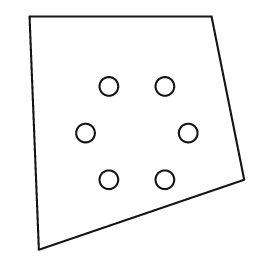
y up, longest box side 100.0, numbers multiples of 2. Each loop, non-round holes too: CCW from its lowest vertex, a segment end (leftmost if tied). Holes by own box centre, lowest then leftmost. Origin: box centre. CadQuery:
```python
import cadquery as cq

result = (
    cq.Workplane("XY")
    .moveTo(-42.0, -50.0)
    .lineTo(46.0, -20.0)
    .lineTo(32.0, 50.0)
    .lineTo(-46.0, 50.0)
    .close()
    .moveTo(-12.0, -20.0)
    .circle(4.0)
    .moveTo(12.0, -20.0)
    .circle(4.0)
    .moveTo(-22.0, 0.0)
    .circle(4.0)
    .moveTo(22.0, 0.0)
    .circle(4.0)
    .moveTo(-12.0, 20.0)
    .circle(4.0)
    .moveTo(12.0, 20.0)
    .circle(4.0)
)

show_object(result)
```